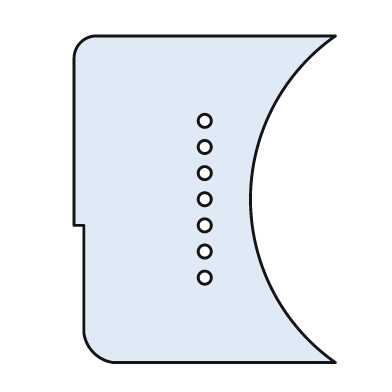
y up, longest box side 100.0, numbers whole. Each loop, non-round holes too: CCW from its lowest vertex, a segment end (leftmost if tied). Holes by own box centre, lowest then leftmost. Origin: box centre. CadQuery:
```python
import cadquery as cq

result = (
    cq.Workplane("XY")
    .moveTo(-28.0, -50.0)
    .lineTo(40.0, -50.0)
    .threePointArc((14.0, 0.0), (40.0, 50.0))
    .lineTo(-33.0, 50.0)
    .threePointArc((-38.0, 48.0), (-40.0, 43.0))
    .lineTo(-40.0, -8.0)
    .lineTo(-37.0, -8.0)
    .lineTo(-37.0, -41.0)
    .threePointArc((-34.0, -47.0), (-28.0, -50.0))
    .close()
    .moveTo(0.0, -24.0)
    .circle(2.0)
    .moveTo(0.0, -16.0)
    .circle(2.0)
    .moveTo(0.0, -8.0)
    .circle(2.0)
    .moveTo(0.0, 0.0)
    .circle(2.0)
    .moveTo(0.0, 8.0)
    .circle(2.0)
    .moveTo(0.0, 16.0)
    .circle(2.0)
    .moveTo(0.0, 24.0)
    .circle(2.0)
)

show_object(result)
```